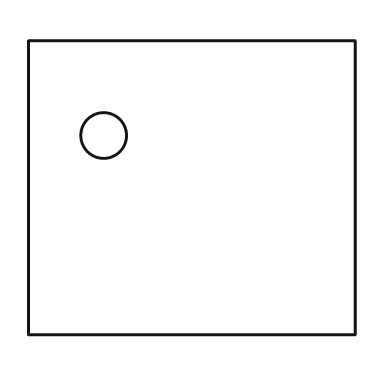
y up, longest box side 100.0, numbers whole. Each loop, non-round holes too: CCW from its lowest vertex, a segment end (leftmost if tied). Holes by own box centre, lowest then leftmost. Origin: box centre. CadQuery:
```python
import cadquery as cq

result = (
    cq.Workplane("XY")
    .moveTo(-50.0, -45.0)
    .lineTo(50.0, -45.0)
    .lineTo(50.0, 45.0)
    .lineTo(-50.0, 45.0)
    .close()
    .moveTo(-27.0, 16.0)
    .circle(7.0)
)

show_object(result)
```